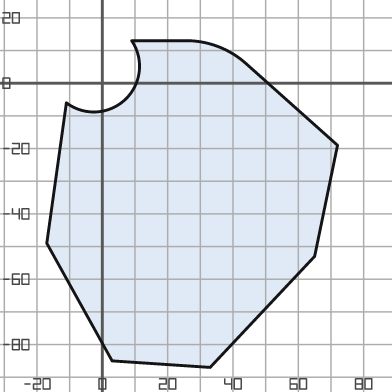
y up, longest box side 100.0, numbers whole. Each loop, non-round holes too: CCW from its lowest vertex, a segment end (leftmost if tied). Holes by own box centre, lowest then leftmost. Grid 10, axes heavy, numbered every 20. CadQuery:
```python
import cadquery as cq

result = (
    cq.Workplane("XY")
    .moveTo(33.0, -87.0)
    .lineTo(65.0, -53.0)
    .lineTo(72.0, -19.0)
    .lineTo(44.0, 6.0)
    .threePointArc((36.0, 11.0), (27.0, 13.0))
    .lineTo(9.0, 13.0)
    .threePointArc((7.0, -5.0), (-11.0, -6.0))
    .lineTo(-17.0, -49.0)
    .lineTo(3.0, -85.0)
    .close()
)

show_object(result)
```